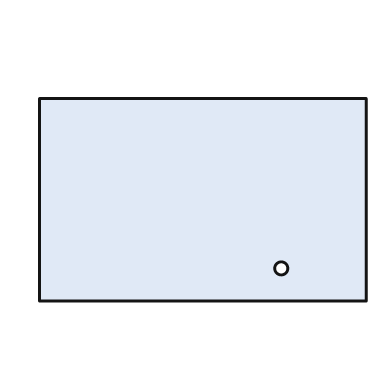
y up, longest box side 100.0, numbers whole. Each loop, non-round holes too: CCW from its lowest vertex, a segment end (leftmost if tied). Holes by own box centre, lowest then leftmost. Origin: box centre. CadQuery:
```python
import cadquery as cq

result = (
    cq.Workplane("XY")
    .moveTo(-50.0, -31.0)
    .lineTo(50.0, -31.0)
    .lineTo(50.0, 31.0)
    .lineTo(-50.0, 31.0)
    .close()
    .moveTo(24.0, -21.0)
    .circle(2.0)
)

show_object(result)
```